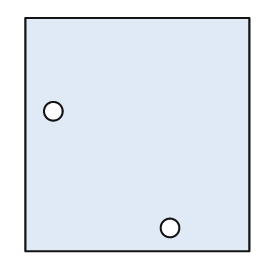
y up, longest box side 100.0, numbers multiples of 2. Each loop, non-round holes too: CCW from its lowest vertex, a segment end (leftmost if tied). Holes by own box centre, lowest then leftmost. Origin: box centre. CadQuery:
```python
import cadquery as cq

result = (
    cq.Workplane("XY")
    .moveTo(-48.0, -50.0)
    .lineTo(48.0, -50.0)
    .lineTo(48.0, 50.0)
    .lineTo(-48.0, 50.0)
    .close()
    .moveTo(14.0, -40.0)
    .circle(4.0)
    .moveTo(-36.0, 10.0)
    .circle(4.0)
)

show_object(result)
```